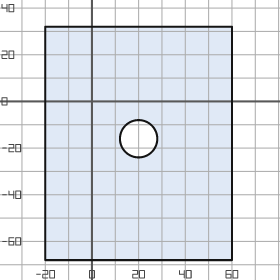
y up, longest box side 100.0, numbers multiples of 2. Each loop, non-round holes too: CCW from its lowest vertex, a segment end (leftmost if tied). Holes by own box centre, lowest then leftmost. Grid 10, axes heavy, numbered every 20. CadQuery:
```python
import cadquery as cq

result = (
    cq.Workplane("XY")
    .moveTo(-20.0, -68.0)
    .lineTo(60.0, -68.0)
    .lineTo(60.0, 32.0)
    .lineTo(-20.0, 32.0)
    .close()
    .moveTo(20.0, -16.0)
    .circle(8.0)
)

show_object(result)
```